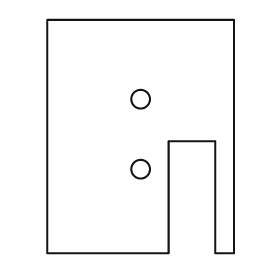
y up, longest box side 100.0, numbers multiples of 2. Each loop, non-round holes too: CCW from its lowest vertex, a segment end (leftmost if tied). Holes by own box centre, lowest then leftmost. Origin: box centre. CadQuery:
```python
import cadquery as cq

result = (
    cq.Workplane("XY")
    .moveTo(-40.0, -50.0)
    .lineTo(12.0, -50.0)
    .lineTo(12.0, -2.0)
    .lineTo(32.0, -2.0)
    .lineTo(32.0, -50.0)
    .lineTo(40.0, -50.0)
    .lineTo(40.0, 50.0)
    .lineTo(-40.0, 50.0)
    .close()
    .moveTo(0.0, -14.0)
    .circle(4.0)
    .moveTo(0.0, 16.0)
    .circle(4.0)
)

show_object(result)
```